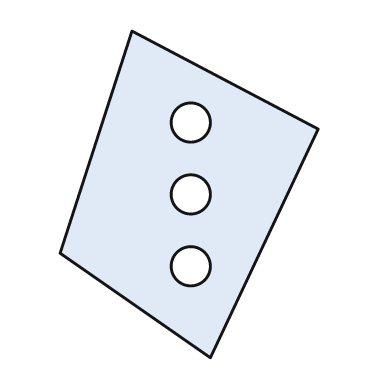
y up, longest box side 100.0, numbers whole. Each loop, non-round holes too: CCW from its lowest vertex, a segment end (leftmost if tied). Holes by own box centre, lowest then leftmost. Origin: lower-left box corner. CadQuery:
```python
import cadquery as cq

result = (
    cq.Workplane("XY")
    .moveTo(46.0, 0.0)
    .lineTo(79.0, 70.0)
    .lineTo(22.0, 100.0)
    .lineTo(0.0, 32.0)
    .close()
    .moveTo(40.0, 28.0)
    .circle(6.0)
    .moveTo(40.0, 50.0)
    .circle(6.0)
    .moveTo(40.0, 72.0)
    .circle(6.0)
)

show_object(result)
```